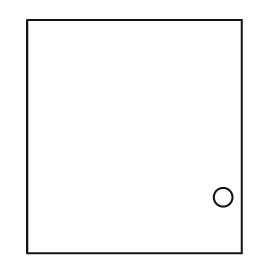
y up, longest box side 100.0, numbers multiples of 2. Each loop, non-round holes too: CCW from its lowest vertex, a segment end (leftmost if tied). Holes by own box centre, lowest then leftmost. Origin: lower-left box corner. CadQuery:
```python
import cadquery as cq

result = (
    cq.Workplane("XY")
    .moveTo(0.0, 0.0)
    .lineTo(92.0, 0.0)
    .lineTo(92.0, 100.0)
    .lineTo(0.0, 100.0)
    .close()
    .moveTo(84.0, 24.0)
    .circle(4.0)
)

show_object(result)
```